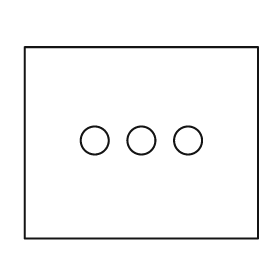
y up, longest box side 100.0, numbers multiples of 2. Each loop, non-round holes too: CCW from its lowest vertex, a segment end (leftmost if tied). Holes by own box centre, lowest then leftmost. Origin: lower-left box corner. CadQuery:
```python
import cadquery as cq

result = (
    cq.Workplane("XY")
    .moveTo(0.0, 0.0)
    .lineTo(100.0, 0.0)
    .lineTo(100.0, 82.0)
    .lineTo(0.0, 82.0)
    .close()
    .moveTo(30.0, 42.0)
    .circle(6.0)
    .moveTo(50.0, 42.0)
    .circle(6.0)
    .moveTo(70.0, 42.0)
    .circle(6.0)
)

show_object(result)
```